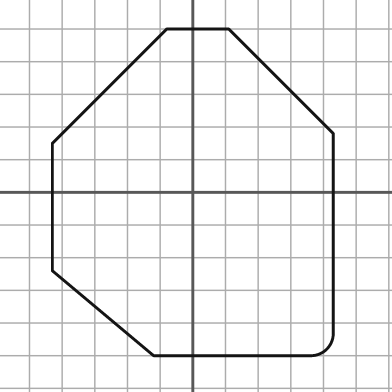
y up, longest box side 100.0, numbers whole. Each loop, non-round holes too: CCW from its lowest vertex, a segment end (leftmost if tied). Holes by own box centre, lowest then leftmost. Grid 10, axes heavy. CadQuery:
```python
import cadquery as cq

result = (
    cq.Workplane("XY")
    .moveTo(-12.0, -50.0)
    .lineTo(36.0, -50.0)
    .threePointArc((41.0, -48.0), (43.0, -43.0))
    .lineTo(43.0, 18.0)
    .lineTo(11.0, 50.0)
    .lineTo(-8.0, 50.0)
    .lineTo(-43.0, 15.0)
    .lineTo(-43.0, -24.0)
    .close()
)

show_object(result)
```